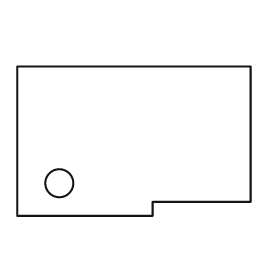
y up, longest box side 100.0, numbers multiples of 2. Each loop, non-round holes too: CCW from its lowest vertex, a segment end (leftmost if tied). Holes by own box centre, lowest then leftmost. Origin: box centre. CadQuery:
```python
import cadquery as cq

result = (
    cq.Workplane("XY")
    .moveTo(-50.0, -32.0)
    .lineTo(8.0, -32.0)
    .lineTo(8.0, -26.0)
    .lineTo(50.0, -26.0)
    .lineTo(50.0, 32.0)
    .lineTo(-50.0, 32.0)
    .close()
    .moveTo(-32.0, -18.0)
    .circle(6.0)
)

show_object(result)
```